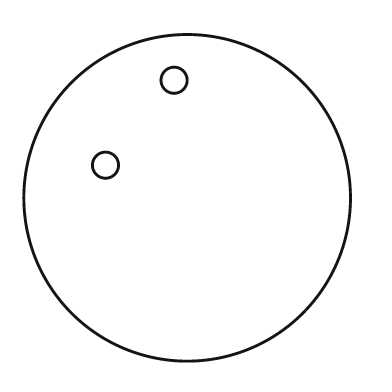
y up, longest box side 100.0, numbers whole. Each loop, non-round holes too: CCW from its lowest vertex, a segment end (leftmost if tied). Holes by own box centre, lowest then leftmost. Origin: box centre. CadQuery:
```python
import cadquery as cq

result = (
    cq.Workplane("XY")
    .moveTo(0.0, 0.0)
    .circle(50.0)
    .moveTo(-25.0, 10.0)
    .circle(4.0)
    .moveTo(-4.0, 36.0)
    .circle(4.0)
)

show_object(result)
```